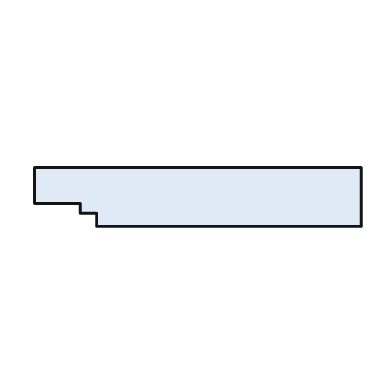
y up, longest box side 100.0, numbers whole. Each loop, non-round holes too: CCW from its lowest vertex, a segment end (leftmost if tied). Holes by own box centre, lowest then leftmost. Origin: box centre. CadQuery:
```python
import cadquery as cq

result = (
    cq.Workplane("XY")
    .moveTo(-31.0, -9.0)
    .lineTo(50.0, -9.0)
    .lineTo(50.0, 9.0)
    .lineTo(-50.0, 9.0)
    .lineTo(-50.0, -2.0)
    .lineTo(-36.0, -2.0)
    .lineTo(-36.0, -5.0)
    .lineTo(-31.0, -5.0)
    .close()
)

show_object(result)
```